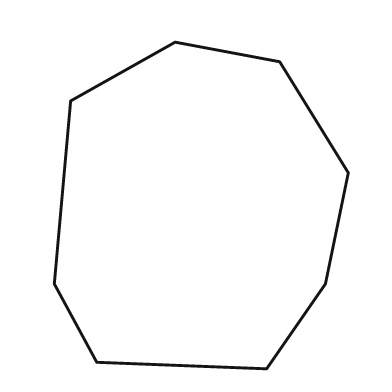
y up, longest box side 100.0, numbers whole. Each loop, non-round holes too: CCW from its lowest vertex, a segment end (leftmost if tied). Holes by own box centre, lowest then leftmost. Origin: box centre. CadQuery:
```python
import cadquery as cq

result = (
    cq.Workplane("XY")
    .moveTo(20.0, -50.0)
    .lineTo(38.0, -24.0)
    .lineTo(45.0, 10.0)
    .lineTo(24.0, 44.0)
    .lineTo(-8.0, 50.0)
    .lineTo(-40.0, 32.0)
    .lineTo(-45.0, -24.0)
    .lineTo(-32.0, -48.0)
    .close()
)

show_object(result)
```